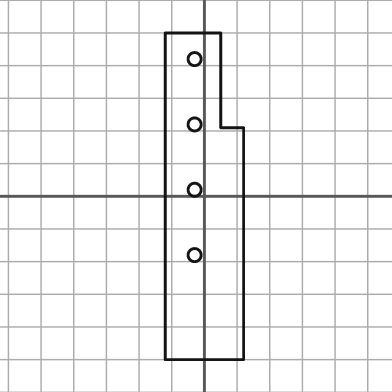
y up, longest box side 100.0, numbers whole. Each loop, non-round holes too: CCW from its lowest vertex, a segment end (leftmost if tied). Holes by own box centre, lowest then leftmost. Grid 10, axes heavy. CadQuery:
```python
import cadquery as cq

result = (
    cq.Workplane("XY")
    .moveTo(-12.0, -50.0)
    .lineTo(12.0, -50.0)
    .lineTo(12.0, 21.0)
    .lineTo(5.0, 21.0)
    .lineTo(5.0, 50.0)
    .lineTo(-12.0, 50.0)
    .close()
    .moveTo(-3.0, -18.0)
    .circle(2.0)
    .moveTo(-3.0, 2.0)
    .circle(2.0)
    .moveTo(-3.0, 22.0)
    .circle(2.0)
    .moveTo(-3.0, 42.0)
    .circle(2.0)
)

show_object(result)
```